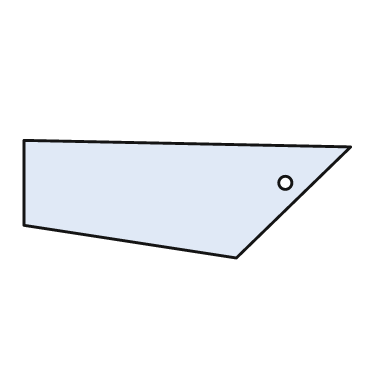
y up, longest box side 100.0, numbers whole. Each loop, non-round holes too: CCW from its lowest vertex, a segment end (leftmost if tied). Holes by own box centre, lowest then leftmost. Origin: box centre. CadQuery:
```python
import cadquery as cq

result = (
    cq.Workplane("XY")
    .moveTo(15.0, -18.0)
    .lineTo(50.0, 16.0)
    .lineTo(-50.0, 18.0)
    .lineTo(-50.0, -8.0)
    .close()
    .moveTo(30.0, 5.0)
    .circle(2.0)
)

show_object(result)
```